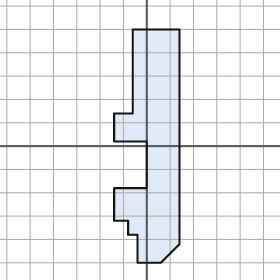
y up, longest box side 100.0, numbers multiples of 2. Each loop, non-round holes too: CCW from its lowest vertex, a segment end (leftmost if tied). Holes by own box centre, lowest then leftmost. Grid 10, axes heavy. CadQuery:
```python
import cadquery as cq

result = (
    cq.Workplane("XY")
    .moveTo(-4.0, -50.0)
    .lineTo(6.0, -50.0)
    .lineTo(14.0, -42.0)
    .lineTo(14.0, 50.0)
    .lineTo(-6.0, 50.0)
    .lineTo(-6.0, 14.0)
    .lineTo(-14.0, 14.0)
    .lineTo(-14.0, 2.0)
    .lineTo(0.0, 2.0)
    .lineTo(0.0, -18.0)
    .lineTo(-14.0, -18.0)
    .lineTo(-14.0, -32.0)
    .lineTo(-8.0, -32.0)
    .lineTo(-8.0, -38.0)
    .lineTo(-4.0, -38.0)
    .close()
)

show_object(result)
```